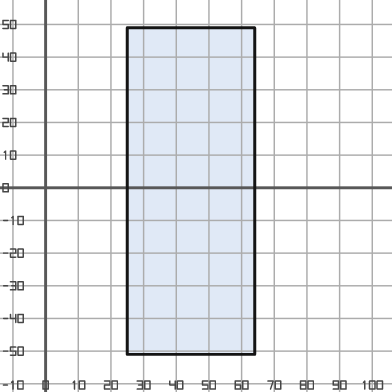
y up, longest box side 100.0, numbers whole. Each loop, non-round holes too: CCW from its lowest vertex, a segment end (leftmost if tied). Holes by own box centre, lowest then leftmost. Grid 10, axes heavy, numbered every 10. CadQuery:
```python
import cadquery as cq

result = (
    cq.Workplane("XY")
    .moveTo(25.0, -51.0)
    .lineTo(64.0, -51.0)
    .lineTo(64.0, 49.0)
    .lineTo(25.0, 49.0)
    .close()
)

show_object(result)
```